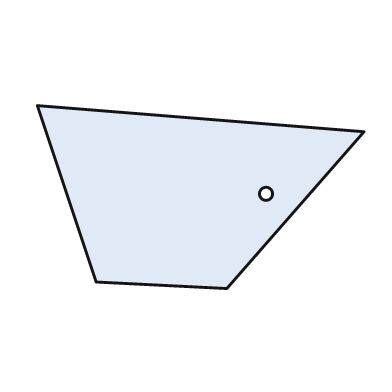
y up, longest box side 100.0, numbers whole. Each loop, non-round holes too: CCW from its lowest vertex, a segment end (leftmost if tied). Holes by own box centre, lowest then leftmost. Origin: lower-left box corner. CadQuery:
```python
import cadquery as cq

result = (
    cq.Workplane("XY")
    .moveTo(58.0, 0.0)
    .lineTo(100.0, 48.0)
    .lineTo(0.0, 56.0)
    .lineTo(18.0, 2.0)
    .close()
    .moveTo(70.0, 29.0)
    .circle(2.0)
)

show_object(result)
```